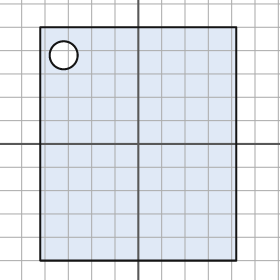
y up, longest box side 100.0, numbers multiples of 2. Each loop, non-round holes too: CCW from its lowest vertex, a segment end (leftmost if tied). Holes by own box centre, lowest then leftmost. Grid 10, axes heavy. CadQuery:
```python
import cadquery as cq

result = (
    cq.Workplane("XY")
    .moveTo(-42.0, -50.0)
    .lineTo(42.0, -50.0)
    .lineTo(42.0, 50.0)
    .lineTo(-42.0, 50.0)
    .close()
    .moveTo(-32.0, 38.0)
    .circle(6.0)
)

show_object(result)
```